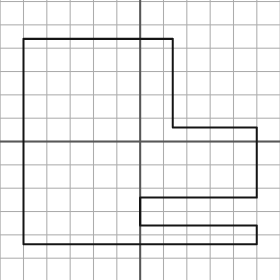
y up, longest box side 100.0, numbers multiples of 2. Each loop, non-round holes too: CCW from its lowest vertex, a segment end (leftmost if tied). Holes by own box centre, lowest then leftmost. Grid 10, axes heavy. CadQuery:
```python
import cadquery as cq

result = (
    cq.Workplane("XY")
    .moveTo(-50.0, -44.0)
    .lineTo(50.0, -44.0)
    .lineTo(50.0, -36.0)
    .lineTo(0.0, -36.0)
    .lineTo(0.0, -24.0)
    .lineTo(50.0, -24.0)
    .lineTo(50.0, 6.0)
    .lineTo(14.0, 6.0)
    .lineTo(14.0, 44.0)
    .lineTo(-50.0, 44.0)
    .close()
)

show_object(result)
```